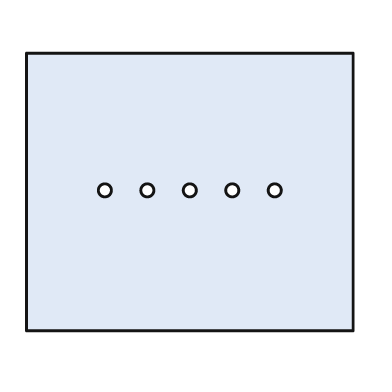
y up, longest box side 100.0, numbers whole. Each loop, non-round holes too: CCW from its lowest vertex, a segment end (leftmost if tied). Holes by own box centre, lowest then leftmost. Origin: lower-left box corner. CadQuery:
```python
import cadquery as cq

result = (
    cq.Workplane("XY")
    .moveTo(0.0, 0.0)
    .lineTo(100.0, 0.0)
    .lineTo(100.0, 85.0)
    .lineTo(0.0, 85.0)
    .close()
    .moveTo(24.0, 43.0)
    .circle(2.0)
    .moveTo(37.0, 43.0)
    .circle(2.0)
    .moveTo(50.0, 43.0)
    .circle(2.0)
    .moveTo(63.0, 43.0)
    .circle(2.0)
    .moveTo(76.0, 43.0)
    .circle(2.0)
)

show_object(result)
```